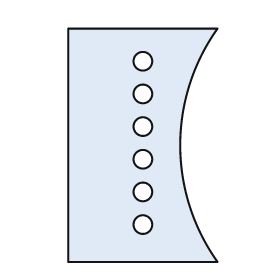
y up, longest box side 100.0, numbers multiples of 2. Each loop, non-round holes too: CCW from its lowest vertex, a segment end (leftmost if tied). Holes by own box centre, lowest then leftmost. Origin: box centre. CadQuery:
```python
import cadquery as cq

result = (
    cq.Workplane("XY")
    .moveTo(-32.0, -50.0)
    .lineTo(32.0, -50.0)
    .threePointArc((16.0, 0.0), (32.0, 50.0))
    .lineTo(-32.0, 50.0)
    .close()
    .moveTo(0.0, -34.0)
    .circle(4.0)
    .moveTo(0.0, -20.0)
    .circle(4.0)
    .moveTo(0.0, -6.0)
    .circle(4.0)
    .moveTo(0.0, 8.0)
    .circle(4.0)
    .moveTo(0.0, 22.0)
    .circle(4.0)
    .moveTo(0.0, 36.0)
    .circle(4.0)
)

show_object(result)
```